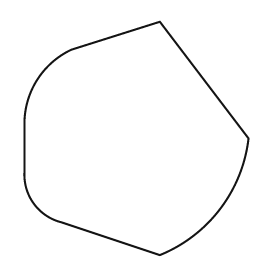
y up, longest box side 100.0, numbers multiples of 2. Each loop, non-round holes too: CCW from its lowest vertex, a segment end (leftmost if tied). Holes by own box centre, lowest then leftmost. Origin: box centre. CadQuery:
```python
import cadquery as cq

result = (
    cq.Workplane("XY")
    .moveTo(10.0, -50.0)
    .threePointArc((36.0, -30.0), (48.0, 0.0))
    .lineTo(10.0, 50.0)
    .lineTo(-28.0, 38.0)
    .threePointArc((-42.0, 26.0), (-48.0, 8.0))
    .lineTo(-48.0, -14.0)
    .threePointArc((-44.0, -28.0), (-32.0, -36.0))
    .close()
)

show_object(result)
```